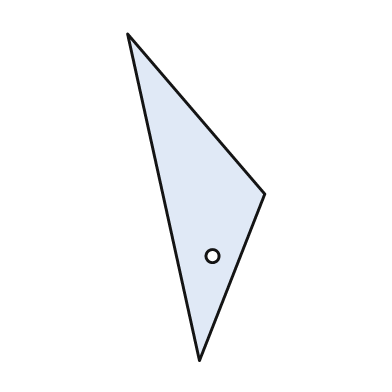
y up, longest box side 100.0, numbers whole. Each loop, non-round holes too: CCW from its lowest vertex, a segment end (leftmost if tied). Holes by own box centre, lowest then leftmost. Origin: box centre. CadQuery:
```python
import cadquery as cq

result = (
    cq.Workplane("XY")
    .moveTo(1.0, -50.0)
    .lineTo(21.0, 1.0)
    .lineTo(-21.0, 50.0)
    .close()
    .moveTo(5.0, -18.0)
    .circle(2.0)
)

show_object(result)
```